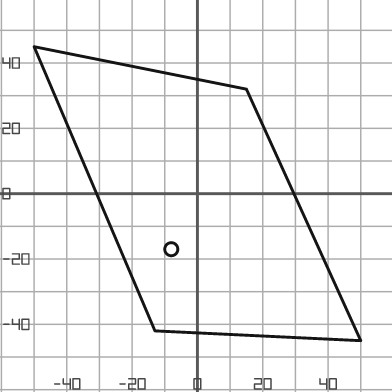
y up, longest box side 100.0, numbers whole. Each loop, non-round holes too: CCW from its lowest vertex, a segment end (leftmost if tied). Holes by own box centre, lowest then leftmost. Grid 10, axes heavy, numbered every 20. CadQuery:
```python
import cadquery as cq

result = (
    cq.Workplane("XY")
    .moveTo(50.0, -45.0)
    .lineTo(15.0, 32.0)
    .lineTo(-50.0, 45.0)
    .lineTo(-13.0, -42.0)
    .close()
    .moveTo(-8.0, -17.0)
    .circle(2.0)
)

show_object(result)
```